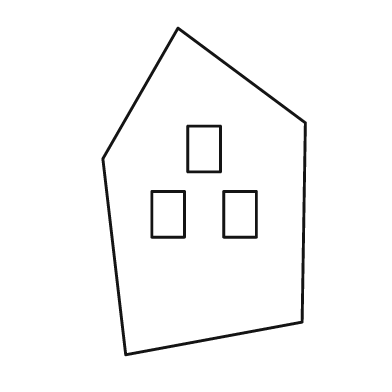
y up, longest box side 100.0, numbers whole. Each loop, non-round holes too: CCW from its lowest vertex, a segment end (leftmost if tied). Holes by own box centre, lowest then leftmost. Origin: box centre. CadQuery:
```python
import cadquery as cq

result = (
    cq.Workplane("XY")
    .moveTo(-24.0, -50.0)
    .lineTo(30.0, -40.0)
    .lineTo(31.0, 21.0)
    .lineTo(-8.0, 50.0)
    .lineTo(-31.0, 10.0)
    .close()
    .moveTo(-16.0, -14.0)
    .lineTo(-6.0, -14.0)
    .lineTo(-6.0, 0.0)
    .lineTo(-16.0, 0.0)
    .close()
    .moveTo(6.0, -14.0)
    .lineTo(16.0, -14.0)
    .lineTo(16.0, 0.0)
    .lineTo(6.0, 0.0)
    .close()
    .moveTo(-5.0, 6.0)
    .lineTo(5.0, 6.0)
    .lineTo(5.0, 20.0)
    .lineTo(-5.0, 20.0)
    .close()
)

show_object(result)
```